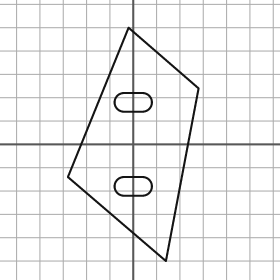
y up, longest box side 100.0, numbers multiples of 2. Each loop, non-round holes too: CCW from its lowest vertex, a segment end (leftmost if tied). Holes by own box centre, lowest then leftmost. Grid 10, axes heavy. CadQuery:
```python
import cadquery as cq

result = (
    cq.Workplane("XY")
    .moveTo(14.0, -50.0)
    .lineTo(28.0, 24.0)
    .lineTo(-2.0, 50.0)
    .lineTo(-28.0, -14.0)
    .close()
    .moveTo(-4.0, -22.0)
    .lineTo(4.0, -22.0)
    .threePointArc((8.0, -18.0), (4.0, -14.0))
    .lineTo(-4.0, -14.0)
    .threePointArc((-8.0, -18.0), (-4.0, -22.0))
    .close()
    .moveTo(-4.0, 14.0)
    .lineTo(4.0, 14.0)
    .threePointArc((8.0, 18.0), (4.0, 22.0))
    .lineTo(-4.0, 22.0)
    .threePointArc((-8.0, 18.0), (-4.0, 14.0))
    .close()
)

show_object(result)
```